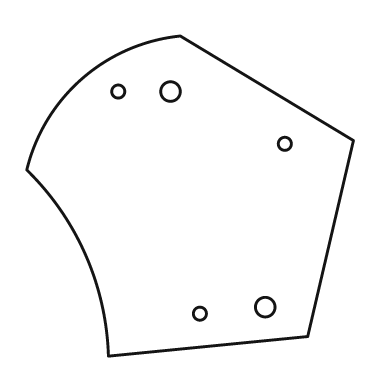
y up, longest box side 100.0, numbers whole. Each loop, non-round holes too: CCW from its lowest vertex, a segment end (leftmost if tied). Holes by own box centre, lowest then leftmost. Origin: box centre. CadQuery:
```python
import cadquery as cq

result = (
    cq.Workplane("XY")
    .moveTo(-25.0, -49.0)
    .lineTo(36.0, -43.0)
    .lineTo(50.0, 17.0)
    .lineTo(-3.0, 49.0)
    .threePointArc((-33.0, 36.0), (-50.0, 8.0))
    .threePointArc((-32.0, -18.0), (-25.0, -49.0))
    .close()
    .moveTo(3.0, -36.0)
    .circle(2.0)
    .moveTo(23.0, -34.0)
    .circle(3.0)
    .moveTo(29.0, 16.0)
    .circle(2.0)
    .moveTo(-22.0, 32.0)
    .circle(2.0)
    .moveTo(-6.0, 32.0)
    .circle(3.0)
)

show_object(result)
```